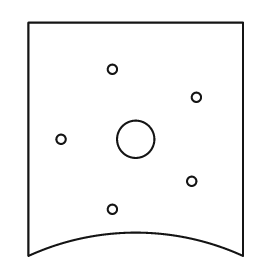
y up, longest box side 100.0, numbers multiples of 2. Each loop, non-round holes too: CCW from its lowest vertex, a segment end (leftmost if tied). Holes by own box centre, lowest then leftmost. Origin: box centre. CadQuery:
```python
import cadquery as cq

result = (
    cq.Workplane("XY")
    .moveTo(-46.0, -50.0)
    .threePointArc((0.0, -40.0), (46.0, -50.0))
    .lineTo(46.0, 50.0)
    .lineTo(-46.0, 50.0)
    .close()
    .moveTo(-10.0, -30.0)
    .circle(2.0)
    .moveTo(24.0, -18.0)
    .circle(2.0)
    .moveTo(-32.0, 0.0)
    .circle(2.0)
    .moveTo(0.0, 0.0)
    .circle(8.0)
    .moveTo(26.0, 18.0)
    .circle(2.0)
    .moveTo(-10.0, 30.0)
    .circle(2.0)
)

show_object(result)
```